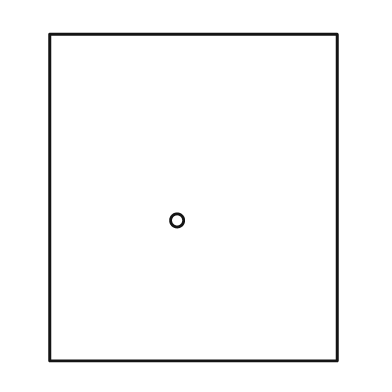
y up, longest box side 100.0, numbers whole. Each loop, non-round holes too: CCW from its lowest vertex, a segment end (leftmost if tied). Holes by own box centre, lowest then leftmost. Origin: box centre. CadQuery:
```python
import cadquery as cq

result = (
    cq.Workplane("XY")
    .moveTo(-44.0, -50.0)
    .lineTo(44.0, -50.0)
    .lineTo(44.0, 50.0)
    .lineTo(-44.0, 50.0)
    .close()
    .moveTo(-5.0, -7.0)
    .circle(2.0)
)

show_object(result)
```